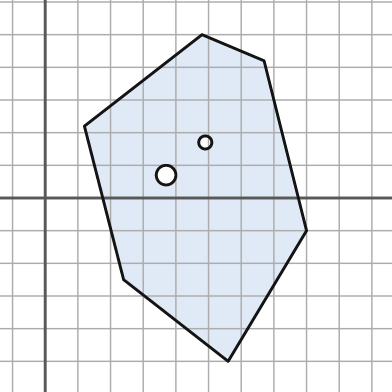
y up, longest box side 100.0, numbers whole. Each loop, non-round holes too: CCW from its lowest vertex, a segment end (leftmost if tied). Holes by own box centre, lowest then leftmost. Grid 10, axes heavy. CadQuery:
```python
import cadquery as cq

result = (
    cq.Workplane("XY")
    .moveTo(56.0, -50.0)
    .lineTo(80.0, -10.0)
    .lineTo(67.0, 42.0)
    .lineTo(48.0, 50.0)
    .lineTo(12.0, 22.0)
    .lineTo(24.0, -25.0)
    .close()
    .moveTo(37.0, 7.0)
    .circle(3.0)
    .moveTo(49.0, 17.0)
    .circle(2.0)
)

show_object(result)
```